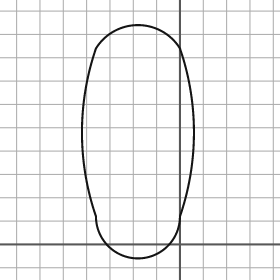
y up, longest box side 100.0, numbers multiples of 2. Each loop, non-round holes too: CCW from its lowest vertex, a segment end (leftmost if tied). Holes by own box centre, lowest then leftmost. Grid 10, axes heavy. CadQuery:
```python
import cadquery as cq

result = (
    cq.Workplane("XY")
    .moveTo(-36.0, 12.0)
    .threePointArc((-18.0, -6.0), (0.0, 12.0))
    .threePointArc((6.0, 48.0), (0.0, 84.0))
    .threePointArc((-18.0, 94.0), (-36.0, 84.0))
    .threePointArc((-42.0, 48.0), (-36.0, 12.0))
    .close()
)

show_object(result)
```